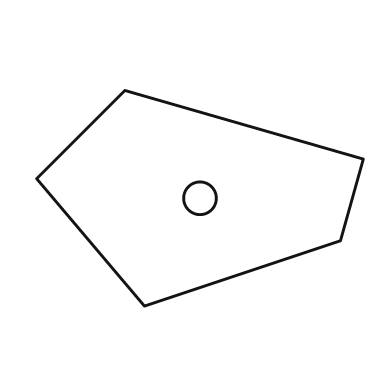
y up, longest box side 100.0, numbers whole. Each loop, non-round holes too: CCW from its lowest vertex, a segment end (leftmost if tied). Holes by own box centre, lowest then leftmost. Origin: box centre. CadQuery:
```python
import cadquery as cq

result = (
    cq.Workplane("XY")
    .moveTo(-17.0, -33.0)
    .lineTo(43.0, -13.0)
    .lineTo(50.0, 12.0)
    .lineTo(-23.0, 33.0)
    .lineTo(-50.0, 6.0)
    .close()
    .moveTo(0.0, 0.0)
    .circle(5.0)
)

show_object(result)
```